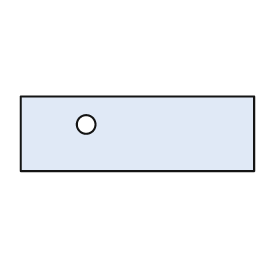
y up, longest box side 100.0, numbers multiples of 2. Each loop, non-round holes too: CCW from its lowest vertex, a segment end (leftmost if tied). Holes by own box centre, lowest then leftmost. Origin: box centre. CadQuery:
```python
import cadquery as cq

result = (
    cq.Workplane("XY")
    .moveTo(-50.0, -16.0)
    .lineTo(50.0, -16.0)
    .lineTo(50.0, 16.0)
    .lineTo(-50.0, 16.0)
    .close()
    .moveTo(-22.0, 4.0)
    .circle(4.0)
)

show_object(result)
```